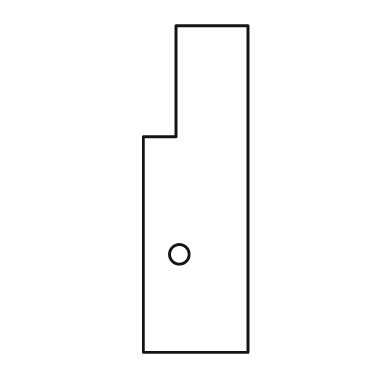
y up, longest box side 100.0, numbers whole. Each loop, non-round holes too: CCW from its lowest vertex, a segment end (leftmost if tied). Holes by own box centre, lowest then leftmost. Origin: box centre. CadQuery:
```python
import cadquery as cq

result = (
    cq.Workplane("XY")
    .moveTo(-16.0, -50.0)
    .lineTo(16.0, -50.0)
    .lineTo(16.0, 50.0)
    .lineTo(-6.0, 50.0)
    .lineTo(-6.0, 16.0)
    .lineTo(-16.0, 16.0)
    .close()
    .moveTo(-5.0, -20.0)
    .circle(3.0)
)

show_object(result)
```